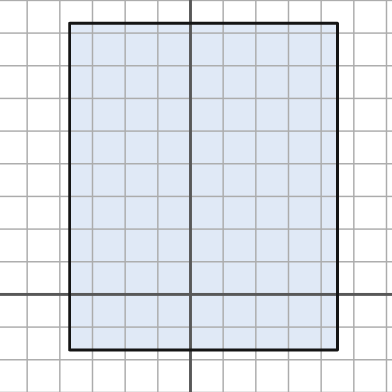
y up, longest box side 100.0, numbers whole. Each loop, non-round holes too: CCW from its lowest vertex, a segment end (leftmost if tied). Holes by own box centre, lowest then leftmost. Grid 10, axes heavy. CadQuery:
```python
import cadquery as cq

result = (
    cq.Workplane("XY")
    .moveTo(-37.0, -17.0)
    .lineTo(45.0, -17.0)
    .lineTo(45.0, 83.0)
    .lineTo(-37.0, 83.0)
    .close()
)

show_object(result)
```